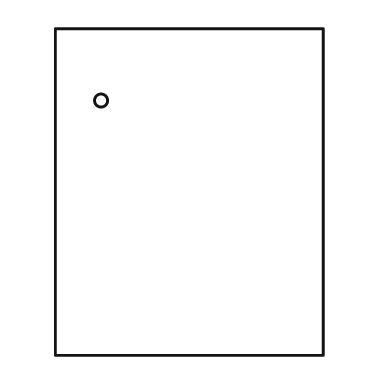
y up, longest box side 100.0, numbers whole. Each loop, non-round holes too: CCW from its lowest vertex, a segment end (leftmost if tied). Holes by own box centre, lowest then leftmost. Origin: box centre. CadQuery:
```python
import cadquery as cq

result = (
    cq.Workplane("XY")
    .moveTo(-41.0, -50.0)
    .lineTo(41.0, -50.0)
    .lineTo(41.0, 50.0)
    .lineTo(-41.0, 50.0)
    .close()
    .moveTo(-27.0, 28.0)
    .circle(2.0)
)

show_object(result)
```